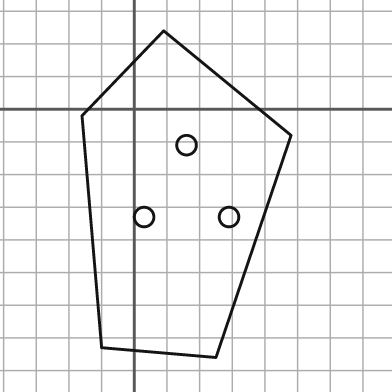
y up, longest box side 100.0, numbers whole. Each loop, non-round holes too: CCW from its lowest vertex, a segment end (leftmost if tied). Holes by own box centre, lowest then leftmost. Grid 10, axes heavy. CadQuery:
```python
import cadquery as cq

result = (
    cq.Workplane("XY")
    .moveTo(25.0, -76.0)
    .lineTo(48.0, -8.0)
    .lineTo(9.0, 24.0)
    .lineTo(-16.0, -2.0)
    .lineTo(-10.0, -73.0)
    .close()
    .moveTo(3.0, -33.0)
    .circle(3.0)
    .moveTo(29.0, -33.0)
    .circle(3.0)
    .moveTo(16.0, -11.0)
    .circle(3.0)
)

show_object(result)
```